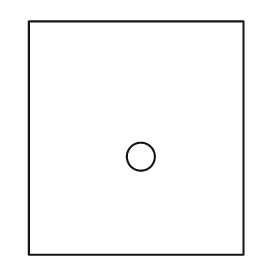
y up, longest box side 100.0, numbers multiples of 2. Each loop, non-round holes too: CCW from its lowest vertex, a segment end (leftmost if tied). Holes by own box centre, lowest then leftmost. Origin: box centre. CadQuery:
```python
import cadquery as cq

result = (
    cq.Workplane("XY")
    .moveTo(-46.0, -50.0)
    .lineTo(46.0, -50.0)
    .lineTo(46.0, 50.0)
    .lineTo(-46.0, 50.0)
    .close()
    .moveTo(2.0, -8.0)
    .circle(6.0)
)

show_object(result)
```